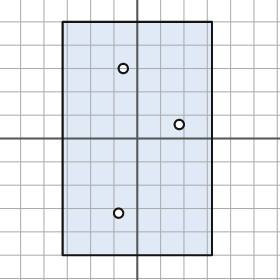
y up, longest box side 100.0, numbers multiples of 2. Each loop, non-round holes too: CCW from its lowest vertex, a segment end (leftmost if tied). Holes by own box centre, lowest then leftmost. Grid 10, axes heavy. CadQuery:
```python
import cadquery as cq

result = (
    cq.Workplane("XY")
    .moveTo(-32.0, -50.0)
    .lineTo(32.0, -50.0)
    .lineTo(32.0, 50.0)
    .lineTo(-32.0, 50.0)
    .close()
    .moveTo(-8.0, -32.0)
    .circle(2.0)
    .moveTo(18.0, 6.0)
    .circle(2.0)
    .moveTo(-6.0, 30.0)
    .circle(2.0)
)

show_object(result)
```